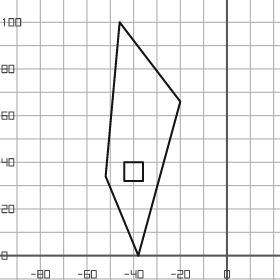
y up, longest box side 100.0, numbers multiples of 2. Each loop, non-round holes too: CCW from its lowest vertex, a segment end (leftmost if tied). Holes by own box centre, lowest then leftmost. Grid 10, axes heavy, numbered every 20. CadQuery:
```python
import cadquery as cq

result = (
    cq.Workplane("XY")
    .moveTo(-38.0, 0.0)
    .lineTo(-20.0, 66.0)
    .lineTo(-46.0, 100.0)
    .lineTo(-52.0, 34.0)
    .close()
    .moveTo(-44.0, 32.0)
    .lineTo(-36.0, 32.0)
    .lineTo(-36.0, 40.0)
    .lineTo(-44.0, 40.0)
    .close()
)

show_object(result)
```